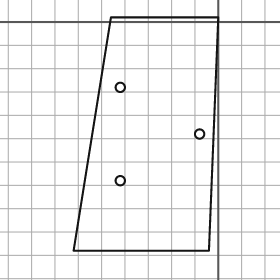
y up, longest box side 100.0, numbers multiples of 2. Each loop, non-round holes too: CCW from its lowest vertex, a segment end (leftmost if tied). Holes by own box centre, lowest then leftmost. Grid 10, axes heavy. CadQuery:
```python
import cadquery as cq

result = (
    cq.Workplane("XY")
    .moveTo(-62.0, -98.0)
    .lineTo(-4.0, -98.0)
    .lineTo(0.0, 2.0)
    .lineTo(-46.0, 2.0)
    .close()
    .moveTo(-42.0, -68.0)
    .circle(2.0)
    .moveTo(-8.0, -48.0)
    .circle(2.0)
    .moveTo(-42.0, -28.0)
    .circle(2.0)
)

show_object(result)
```